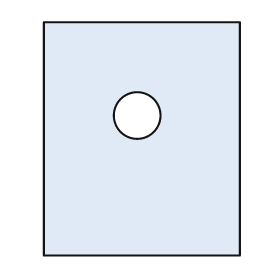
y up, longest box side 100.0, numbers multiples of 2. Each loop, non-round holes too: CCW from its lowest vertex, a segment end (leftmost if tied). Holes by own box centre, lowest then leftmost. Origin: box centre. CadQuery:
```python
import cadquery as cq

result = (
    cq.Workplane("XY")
    .moveTo(-42.0, -50.0)
    .lineTo(42.0, -50.0)
    .lineTo(42.0, 50.0)
    .lineTo(-42.0, 50.0)
    .close()
    .moveTo(-2.0, 10.0)
    .circle(10.0)
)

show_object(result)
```